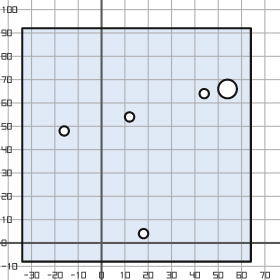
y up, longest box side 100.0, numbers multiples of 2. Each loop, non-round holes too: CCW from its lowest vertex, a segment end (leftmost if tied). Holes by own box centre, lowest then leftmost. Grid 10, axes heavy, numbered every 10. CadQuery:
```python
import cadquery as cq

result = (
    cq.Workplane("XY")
    .moveTo(-34.0, -8.0)
    .lineTo(64.0, -8.0)
    .lineTo(64.0, 92.0)
    .lineTo(-34.0, 92.0)
    .close()
    .moveTo(18.0, 4.0)
    .circle(2.0)
    .moveTo(-16.0, 48.0)
    .circle(2.0)
    .moveTo(12.0, 54.0)
    .circle(2.0)
    .moveTo(44.0, 64.0)
    .circle(2.0)
    .moveTo(54.0, 66.0)
    .circle(4.0)
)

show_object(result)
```